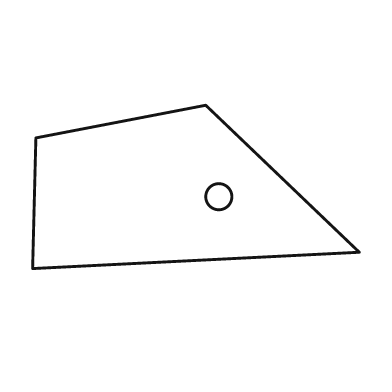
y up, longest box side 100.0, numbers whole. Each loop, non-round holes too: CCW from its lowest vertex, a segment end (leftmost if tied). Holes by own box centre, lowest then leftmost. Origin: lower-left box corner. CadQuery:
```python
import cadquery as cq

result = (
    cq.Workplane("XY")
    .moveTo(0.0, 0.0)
    .lineTo(100.0, 5.0)
    .lineTo(53.0, 50.0)
    .lineTo(1.0, 40.0)
    .close()
    .moveTo(57.0, 22.0)
    .circle(4.0)
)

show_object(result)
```